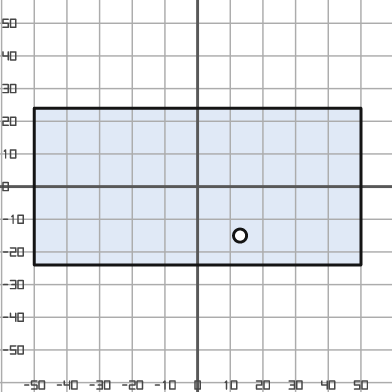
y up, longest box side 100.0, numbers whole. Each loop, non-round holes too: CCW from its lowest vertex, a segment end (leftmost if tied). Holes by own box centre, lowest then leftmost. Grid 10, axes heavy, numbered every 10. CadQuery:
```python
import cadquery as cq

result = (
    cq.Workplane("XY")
    .moveTo(-50.0, -24.0)
    .lineTo(50.0, -24.0)
    .lineTo(50.0, 24.0)
    .lineTo(-50.0, 24.0)
    .close()
    .moveTo(13.0, -15.0)
    .circle(2.0)
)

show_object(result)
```